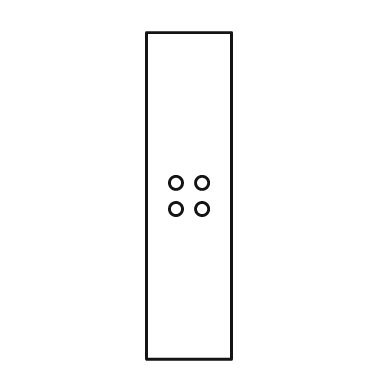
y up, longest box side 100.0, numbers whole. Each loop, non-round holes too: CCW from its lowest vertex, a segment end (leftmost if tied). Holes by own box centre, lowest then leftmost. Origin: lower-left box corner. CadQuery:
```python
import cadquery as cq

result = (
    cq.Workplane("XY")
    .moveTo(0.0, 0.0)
    .lineTo(26.0, 0.0)
    .lineTo(26.0, 100.0)
    .lineTo(0.0, 100.0)
    .close()
    .moveTo(9.0, 46.0)
    .circle(2.0)
    .moveTo(17.0, 46.0)
    .circle(2.0)
    .moveTo(9.0, 54.0)
    .circle(2.0)
    .moveTo(17.0, 54.0)
    .circle(2.0)
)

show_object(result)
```